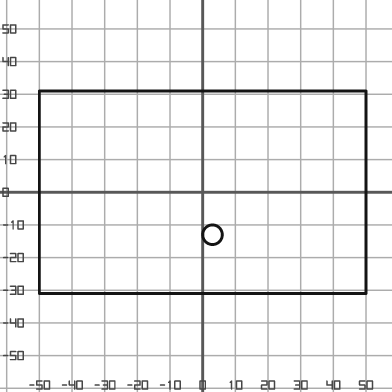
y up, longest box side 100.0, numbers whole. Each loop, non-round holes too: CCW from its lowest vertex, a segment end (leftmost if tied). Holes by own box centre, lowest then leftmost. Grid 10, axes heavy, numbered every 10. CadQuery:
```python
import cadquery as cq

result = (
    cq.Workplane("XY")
    .moveTo(-50.0, -31.0)
    .lineTo(50.0, -31.0)
    .lineTo(50.0, 31.0)
    .lineTo(-50.0, 31.0)
    .close()
    .moveTo(3.0, -13.0)
    .circle(3.0)
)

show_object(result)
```